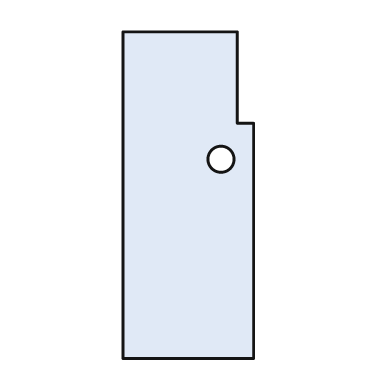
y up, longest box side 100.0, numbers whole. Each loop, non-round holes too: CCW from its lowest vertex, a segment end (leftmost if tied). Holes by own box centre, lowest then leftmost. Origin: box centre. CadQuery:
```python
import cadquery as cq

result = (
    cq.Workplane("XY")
    .moveTo(-20.0, -50.0)
    .lineTo(20.0, -50.0)
    .lineTo(20.0, 22.0)
    .lineTo(15.0, 22.0)
    .lineTo(15.0, 50.0)
    .lineTo(-20.0, 50.0)
    .close()
    .moveTo(10.0, 11.0)
    .circle(4.0)
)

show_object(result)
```